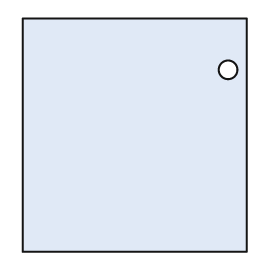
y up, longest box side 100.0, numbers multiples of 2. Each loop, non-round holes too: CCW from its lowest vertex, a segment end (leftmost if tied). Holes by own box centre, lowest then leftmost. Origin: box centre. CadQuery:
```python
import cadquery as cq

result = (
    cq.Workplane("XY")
    .moveTo(-48.0, -50.0)
    .lineTo(48.0, -50.0)
    .lineTo(48.0, 50.0)
    .lineTo(-48.0, 50.0)
    .close()
    .moveTo(40.0, 28.0)
    .circle(4.0)
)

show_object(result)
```